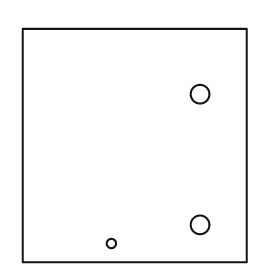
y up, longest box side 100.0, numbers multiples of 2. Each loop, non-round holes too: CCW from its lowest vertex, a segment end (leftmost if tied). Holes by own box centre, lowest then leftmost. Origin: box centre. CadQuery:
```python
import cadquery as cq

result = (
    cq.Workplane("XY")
    .moveTo(-48.0, -50.0)
    .lineTo(48.0, -50.0)
    .lineTo(48.0, 50.0)
    .lineTo(-48.0, 50.0)
    .close()
    .moveTo(-10.0, -42.0)
    .circle(2.0)
    .moveTo(28.0, -34.0)
    .circle(4.0)
    .moveTo(28.0, 22.0)
    .circle(4.0)
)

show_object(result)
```